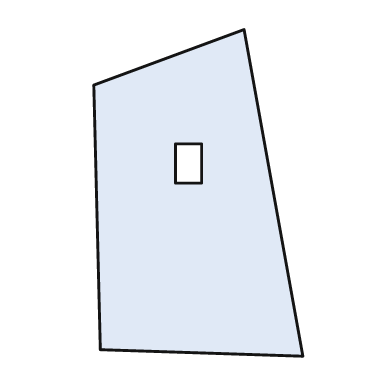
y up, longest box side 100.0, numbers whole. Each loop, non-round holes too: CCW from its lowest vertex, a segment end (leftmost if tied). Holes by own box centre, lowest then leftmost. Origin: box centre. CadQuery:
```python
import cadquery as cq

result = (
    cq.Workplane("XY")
    .moveTo(32.0, -50.0)
    .lineTo(14.0, 50.0)
    .lineTo(-32.0, 33.0)
    .lineTo(-30.0, -48.0)
    .close()
    .moveTo(-7.0, 3.0)
    .lineTo(1.0, 3.0)
    .lineTo(1.0, 15.0)
    .lineTo(-7.0, 15.0)
    .close()
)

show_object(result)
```